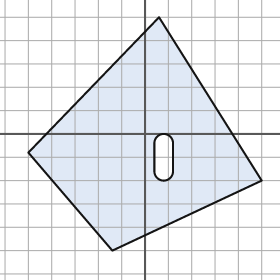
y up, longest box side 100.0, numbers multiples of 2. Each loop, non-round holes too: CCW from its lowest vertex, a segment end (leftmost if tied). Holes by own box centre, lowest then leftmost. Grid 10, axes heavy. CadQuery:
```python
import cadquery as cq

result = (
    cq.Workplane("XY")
    .moveTo(-14.0, -50.0)
    .lineTo(50.0, -20.0)
    .lineTo(6.0, 50.0)
    .lineTo(-50.0, -8.0)
    .close()
    .moveTo(4.0, -16.0)
    .threePointArc((8.0, -20.0), (12.0, -16.0))
    .lineTo(12.0, -4.0)
    .threePointArc((8.0, 0.0), (4.0, -4.0))
    .close()
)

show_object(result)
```